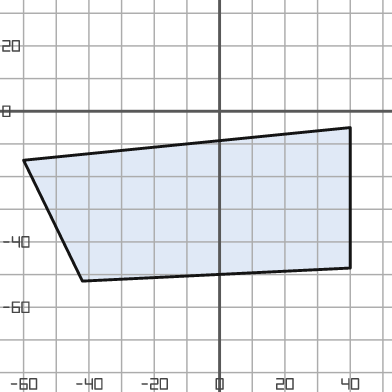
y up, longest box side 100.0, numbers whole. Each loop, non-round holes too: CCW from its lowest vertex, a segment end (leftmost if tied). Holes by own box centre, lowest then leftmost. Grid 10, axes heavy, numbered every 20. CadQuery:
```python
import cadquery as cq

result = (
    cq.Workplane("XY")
    .moveTo(-42.0, -52.0)
    .lineTo(40.0, -48.0)
    .lineTo(40.0, -5.0)
    .lineTo(-60.0, -15.0)
    .close()
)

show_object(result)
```